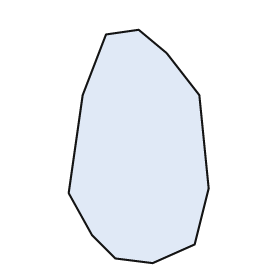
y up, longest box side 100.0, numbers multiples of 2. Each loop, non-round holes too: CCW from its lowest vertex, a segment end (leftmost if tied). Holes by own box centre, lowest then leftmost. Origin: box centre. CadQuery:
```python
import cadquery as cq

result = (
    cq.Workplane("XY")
    .moveTo(6.0, -50.0)
    .lineTo(24.0, -42.0)
    .lineTo(30.0, -18.0)
    .lineTo(26.0, 22.0)
    .lineTo(12.0, 40.0)
    .lineTo(0.0, 50.0)
    .lineTo(-14.0, 48.0)
    .lineTo(-24.0, 22.0)
    .lineTo(-30.0, -20.0)
    .lineTo(-20.0, -38.0)
    .lineTo(-10.0, -48.0)
    .close()
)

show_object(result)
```